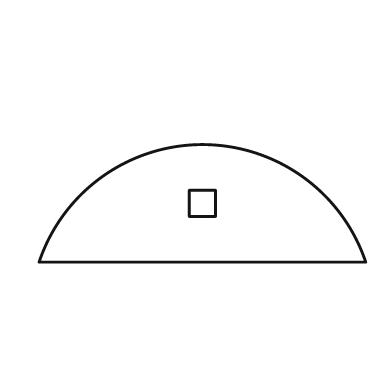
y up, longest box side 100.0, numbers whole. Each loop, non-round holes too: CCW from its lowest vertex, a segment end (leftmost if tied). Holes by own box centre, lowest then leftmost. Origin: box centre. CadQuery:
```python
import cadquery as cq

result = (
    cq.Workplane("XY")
    .moveTo(-50.0, -18.0)
    .lineTo(50.0, -18.0)
    .threePointArc((0.0, 18.0), (-50.0, -18.0))
    .close()
    .moveTo(-4.0, -4.0)
    .lineTo(4.0, -4.0)
    .lineTo(4.0, 4.0)
    .lineTo(-4.0, 4.0)
    .close()
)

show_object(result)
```